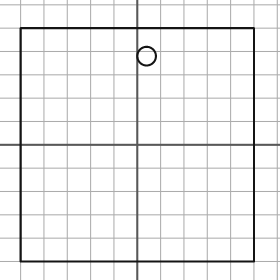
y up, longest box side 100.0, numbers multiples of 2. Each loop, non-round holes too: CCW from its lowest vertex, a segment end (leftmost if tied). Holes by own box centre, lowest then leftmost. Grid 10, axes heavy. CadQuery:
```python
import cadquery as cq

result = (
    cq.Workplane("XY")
    .moveTo(-50.0, -50.0)
    .lineTo(50.0, -50.0)
    .lineTo(50.0, 50.0)
    .lineTo(-50.0, 50.0)
    .close()
    .moveTo(4.0, 38.0)
    .circle(4.0)
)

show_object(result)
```